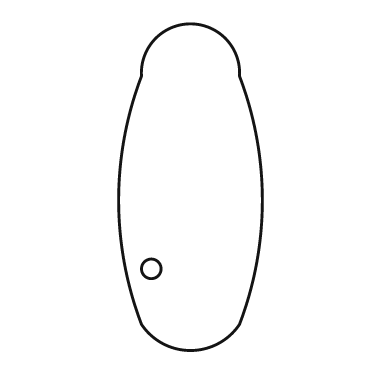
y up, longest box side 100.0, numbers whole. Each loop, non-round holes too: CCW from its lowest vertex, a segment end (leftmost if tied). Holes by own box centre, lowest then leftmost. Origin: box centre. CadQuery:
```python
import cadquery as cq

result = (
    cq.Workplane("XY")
    .moveTo(-15.0, -42.0)
    .threePointArc((0.0, -50.0), (15.0, -42.0))
    .threePointArc((22.0, -4.0), (15.0, 34.0))
    .threePointArc((0.0, 50.0), (-15.0, 34.0))
    .threePointArc((-22.0, -4.0), (-15.0, -42.0))
    .close()
    .moveTo(-12.0, -25.0)
    .circle(3.0)
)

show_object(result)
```